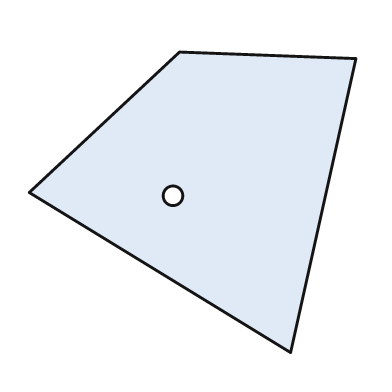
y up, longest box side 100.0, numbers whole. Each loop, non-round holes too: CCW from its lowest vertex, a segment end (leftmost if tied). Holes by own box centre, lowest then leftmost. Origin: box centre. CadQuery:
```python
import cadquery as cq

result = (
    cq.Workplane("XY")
    .moveTo(30.0, -46.0)
    .lineTo(50.0, 44.0)
    .lineTo(-4.0, 46.0)
    .lineTo(-50.0, 3.0)
    .close()
    .moveTo(-6.0, 2.0)
    .circle(3.0)
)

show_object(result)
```